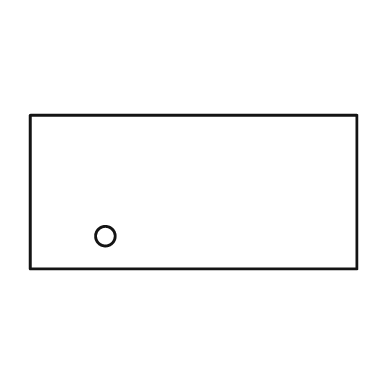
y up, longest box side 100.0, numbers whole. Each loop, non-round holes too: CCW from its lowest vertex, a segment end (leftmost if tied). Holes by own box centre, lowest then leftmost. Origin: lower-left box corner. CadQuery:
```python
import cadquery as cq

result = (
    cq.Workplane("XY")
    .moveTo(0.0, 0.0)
    .lineTo(100.0, 0.0)
    .lineTo(100.0, 47.0)
    .lineTo(0.0, 47.0)
    .close()
    .moveTo(23.0, 10.0)
    .circle(3.0)
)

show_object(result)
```